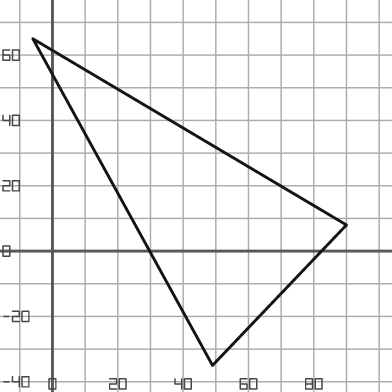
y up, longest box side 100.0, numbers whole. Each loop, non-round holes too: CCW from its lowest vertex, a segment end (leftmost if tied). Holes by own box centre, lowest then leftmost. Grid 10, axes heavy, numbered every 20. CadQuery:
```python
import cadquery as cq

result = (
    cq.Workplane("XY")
    .moveTo(49.0, -35.0)
    .lineTo(90.0, 8.0)
    .lineTo(-6.0, 65.0)
    .close()
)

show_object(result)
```